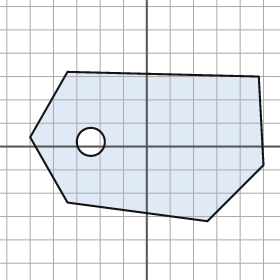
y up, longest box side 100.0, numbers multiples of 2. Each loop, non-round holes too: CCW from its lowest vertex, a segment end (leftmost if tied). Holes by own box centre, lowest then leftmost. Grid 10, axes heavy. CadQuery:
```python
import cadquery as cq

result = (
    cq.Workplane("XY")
    .moveTo(26.0, -32.0)
    .lineTo(50.0, -8.0)
    .lineTo(48.0, 30.0)
    .lineTo(-34.0, 32.0)
    .lineTo(-50.0, 4.0)
    .lineTo(-34.0, -24.0)
    .close()
    .moveTo(-24.0, 2.0)
    .circle(6.0)
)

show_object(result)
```